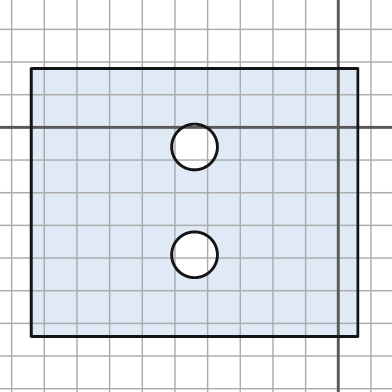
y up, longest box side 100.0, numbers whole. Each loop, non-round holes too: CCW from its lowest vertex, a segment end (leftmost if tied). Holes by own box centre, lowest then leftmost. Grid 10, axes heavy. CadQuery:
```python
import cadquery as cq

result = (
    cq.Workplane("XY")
    .moveTo(-94.0, -64.0)
    .lineTo(6.0, -64.0)
    .lineTo(6.0, 18.0)
    .lineTo(-94.0, 18.0)
    .close()
    .moveTo(-44.0, -39.0)
    .circle(7.0)
    .moveTo(-44.0, -6.0)
    .circle(7.0)
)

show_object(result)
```